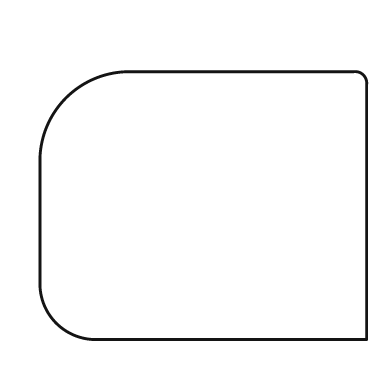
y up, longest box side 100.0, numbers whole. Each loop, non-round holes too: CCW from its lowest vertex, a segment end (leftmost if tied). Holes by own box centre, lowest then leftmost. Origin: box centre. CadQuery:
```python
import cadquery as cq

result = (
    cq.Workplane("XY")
    .moveTo(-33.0, -41.0)
    .lineTo(50.0, -41.0)
    .lineTo(50.0, 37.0)
    .threePointArc((49.0, 40.0), (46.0, 41.0))
    .lineTo(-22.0, 41.0)
    .threePointArc((-42.0, 33.0), (-50.0, 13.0))
    .lineTo(-50.0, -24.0)
    .threePointArc((-45.0, -36.0), (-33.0, -41.0))
    .close()
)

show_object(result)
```